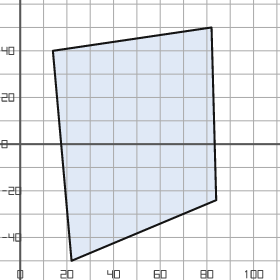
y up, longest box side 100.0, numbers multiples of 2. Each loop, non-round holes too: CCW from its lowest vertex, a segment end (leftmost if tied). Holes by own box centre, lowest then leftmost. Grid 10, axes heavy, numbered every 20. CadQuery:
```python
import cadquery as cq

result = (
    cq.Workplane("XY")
    .moveTo(22.0, -50.0)
    .lineTo(84.0, -24.0)
    .lineTo(82.0, 50.0)
    .lineTo(14.0, 40.0)
    .close()
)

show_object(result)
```